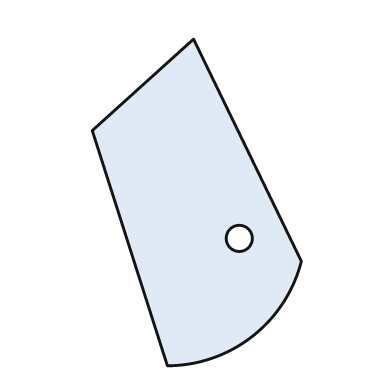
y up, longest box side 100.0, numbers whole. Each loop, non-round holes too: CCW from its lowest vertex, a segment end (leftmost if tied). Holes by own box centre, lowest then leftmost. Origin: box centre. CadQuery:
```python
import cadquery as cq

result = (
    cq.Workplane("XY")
    .moveTo(-9.0, -50.0)
    .threePointArc((17.0, -41.0), (32.0, -18.0))
    .lineTo(-1.0, 50.0)
    .lineTo(-32.0, 22.0)
    .close()
    .moveTo(13.0, -11.0)
    .circle(4.0)
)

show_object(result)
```